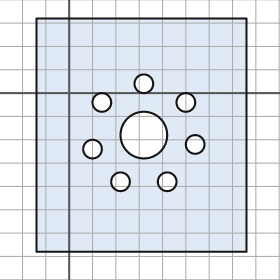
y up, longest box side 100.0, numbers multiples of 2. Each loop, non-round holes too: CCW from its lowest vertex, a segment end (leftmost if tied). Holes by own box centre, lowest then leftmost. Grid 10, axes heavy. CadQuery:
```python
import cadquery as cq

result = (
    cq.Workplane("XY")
    .moveTo(-14.0, -68.0)
    .lineTo(76.0, -68.0)
    .lineTo(76.0, 32.0)
    .lineTo(-14.0, 32.0)
    .close()
    .moveTo(22.0, -38.0)
    .circle(4.0)
    .moveTo(42.0, -38.0)
    .circle(4.0)
    .moveTo(10.0, -24.0)
    .circle(4.0)
    .moveTo(54.0, -22.0)
    .circle(4.0)
    .moveTo(32.0, -18.0)
    .circle(10.0)
    .moveTo(14.0, -4.0)
    .circle(4.0)
    .moveTo(50.0, -4.0)
    .circle(4.0)
    .moveTo(32.0, 4.0)
    .circle(4.0)
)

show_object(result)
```